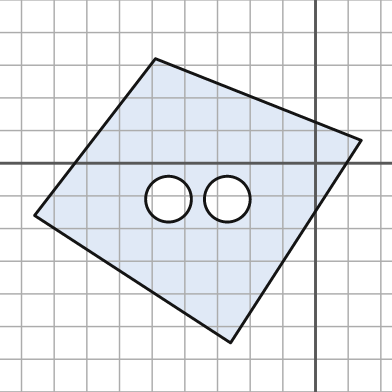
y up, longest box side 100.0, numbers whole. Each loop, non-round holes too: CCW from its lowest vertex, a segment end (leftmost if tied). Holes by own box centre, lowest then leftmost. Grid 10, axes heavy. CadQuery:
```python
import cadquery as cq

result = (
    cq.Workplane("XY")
    .moveTo(-26.0, -55.0)
    .lineTo(14.0, 7.0)
    .lineTo(-49.0, 32.0)
    .lineTo(-86.0, -16.0)
    .close()
    .moveTo(-45.0, -11.0)
    .circle(7.0)
    .moveTo(-27.0, -11.0)
    .circle(7.0)
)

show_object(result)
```